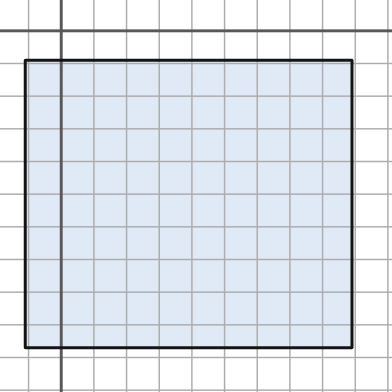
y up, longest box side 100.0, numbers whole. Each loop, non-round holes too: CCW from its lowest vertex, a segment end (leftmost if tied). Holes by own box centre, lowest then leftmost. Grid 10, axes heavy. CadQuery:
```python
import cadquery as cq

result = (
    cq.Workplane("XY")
    .moveTo(-11.0, -97.0)
    .lineTo(89.0, -97.0)
    .lineTo(89.0, -9.0)
    .lineTo(-11.0, -9.0)
    .close()
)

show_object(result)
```